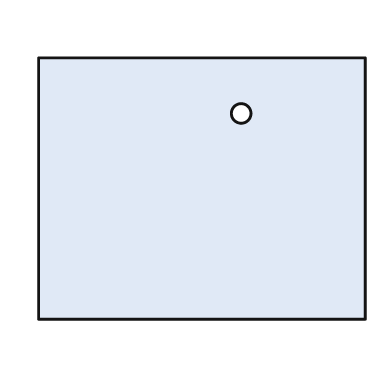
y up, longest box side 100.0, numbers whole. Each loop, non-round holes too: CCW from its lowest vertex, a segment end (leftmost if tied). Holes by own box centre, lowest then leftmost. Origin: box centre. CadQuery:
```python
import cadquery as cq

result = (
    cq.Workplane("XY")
    .moveTo(-50.0, -40.0)
    .lineTo(50.0, -40.0)
    .lineTo(50.0, 40.0)
    .lineTo(-50.0, 40.0)
    .close()
    .moveTo(12.0, 23.0)
    .circle(3.0)
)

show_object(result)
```